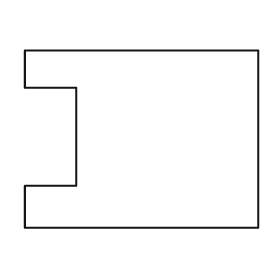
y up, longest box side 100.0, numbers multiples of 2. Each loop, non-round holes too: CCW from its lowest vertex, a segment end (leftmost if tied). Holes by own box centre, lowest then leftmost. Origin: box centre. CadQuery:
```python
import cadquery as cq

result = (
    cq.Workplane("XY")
    .moveTo(-50.0, -38.0)
    .lineTo(50.0, -38.0)
    .lineTo(50.0, 38.0)
    .lineTo(-50.0, 38.0)
    .lineTo(-50.0, 22.0)
    .lineTo(-28.0, 22.0)
    .lineTo(-28.0, -20.0)
    .lineTo(-50.0, -20.0)
    .close()
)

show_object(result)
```